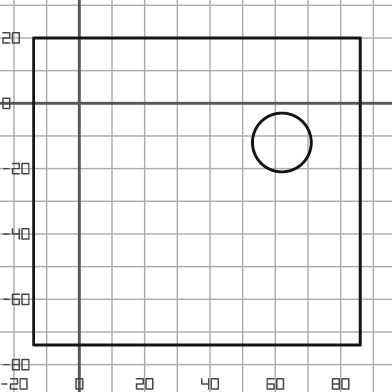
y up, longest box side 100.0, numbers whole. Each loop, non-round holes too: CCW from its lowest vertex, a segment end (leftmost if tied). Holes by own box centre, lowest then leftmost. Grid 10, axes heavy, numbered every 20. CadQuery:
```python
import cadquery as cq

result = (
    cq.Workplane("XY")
    .moveTo(-14.0, -74.0)
    .lineTo(86.0, -74.0)
    .lineTo(86.0, 20.0)
    .lineTo(-14.0, 20.0)
    .close()
    .moveTo(62.0, -12.0)
    .circle(9.0)
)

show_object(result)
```